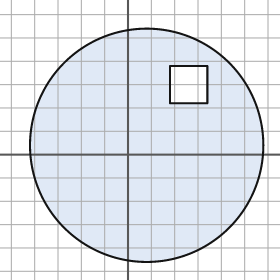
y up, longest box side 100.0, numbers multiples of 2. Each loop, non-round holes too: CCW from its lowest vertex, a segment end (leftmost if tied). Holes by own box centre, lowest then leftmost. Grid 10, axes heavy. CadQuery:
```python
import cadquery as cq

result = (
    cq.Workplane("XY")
    .moveTo(8.0, 4.0)
    .circle(50.0)
    .moveTo(18.0, 22.0)
    .lineTo(34.0, 22.0)
    .lineTo(34.0, 38.0)
    .lineTo(18.0, 38.0)
    .close()
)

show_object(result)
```